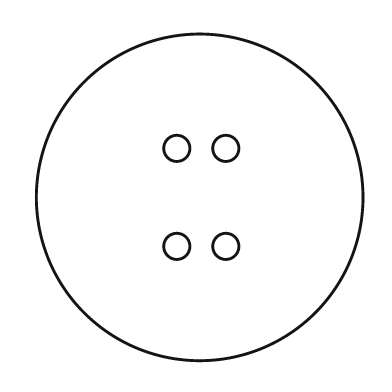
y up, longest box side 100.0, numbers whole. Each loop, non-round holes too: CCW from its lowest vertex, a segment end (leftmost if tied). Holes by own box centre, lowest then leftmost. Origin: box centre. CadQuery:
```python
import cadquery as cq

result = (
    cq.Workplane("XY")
    .moveTo(0.0, 0.0)
    .circle(50.0)
    .moveTo(-7.0, -15.0)
    .circle(4.0)
    .moveTo(8.0, -15.0)
    .circle(4.0)
    .moveTo(-7.0, 15.0)
    .circle(4.0)
    .moveTo(8.0, 15.0)
    .circle(4.0)
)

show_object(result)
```